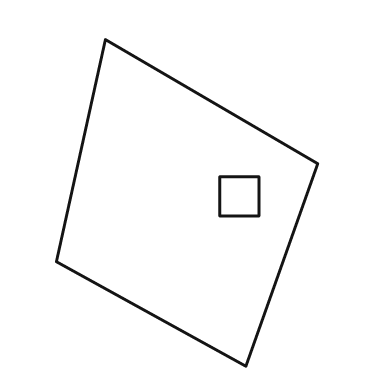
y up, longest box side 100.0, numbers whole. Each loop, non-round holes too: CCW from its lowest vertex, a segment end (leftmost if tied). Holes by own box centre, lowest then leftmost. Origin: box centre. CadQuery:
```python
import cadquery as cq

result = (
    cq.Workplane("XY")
    .moveTo(18.0, -50.0)
    .lineTo(40.0, 12.0)
    .lineTo(-25.0, 50.0)
    .lineTo(-40.0, -18.0)
    .close()
    .moveTo(10.0, -4.0)
    .lineTo(22.0, -4.0)
    .lineTo(22.0, 8.0)
    .lineTo(10.0, 8.0)
    .close()
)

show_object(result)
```